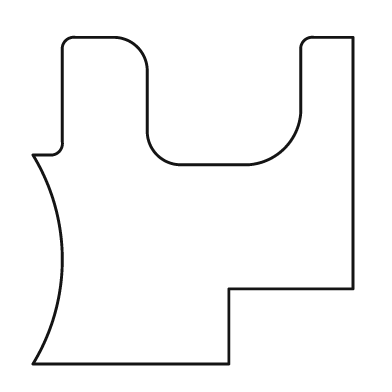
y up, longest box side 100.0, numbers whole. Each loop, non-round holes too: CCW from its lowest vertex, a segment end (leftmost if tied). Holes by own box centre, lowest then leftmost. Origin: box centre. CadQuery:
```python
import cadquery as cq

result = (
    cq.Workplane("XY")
    .moveTo(-49.0, -50.0)
    .lineTo(11.0, -50.0)
    .lineTo(11.0, -27.0)
    .lineTo(49.0, -27.0)
    .lineTo(49.0, 50.0)
    .lineTo(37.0, 50.0)
    .threePointArc((34.0, 49.0), (33.0, 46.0))
    .lineTo(33.0, 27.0)
    .threePointArc((28.0, 16.0), (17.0, 11.0))
    .lineTo(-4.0, 11.0)
    .threePointArc((-11.0, 14.0), (-14.0, 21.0))
    .lineTo(-14.0, 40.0)
    .threePointArc((-17.0, 47.0), (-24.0, 50.0))
    .lineTo(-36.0, 50.0)
    .threePointArc((-39.0, 49.0), (-40.0, 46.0))
    .lineTo(-40.0, 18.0)
    .threePointArc((-41.0, 15.0), (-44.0, 14.0))
    .lineTo(-49.0, 14.0)
    .threePointArc((-40.0, -18.0), (-49.0, -50.0))
    .close()
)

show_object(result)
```